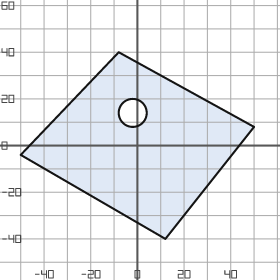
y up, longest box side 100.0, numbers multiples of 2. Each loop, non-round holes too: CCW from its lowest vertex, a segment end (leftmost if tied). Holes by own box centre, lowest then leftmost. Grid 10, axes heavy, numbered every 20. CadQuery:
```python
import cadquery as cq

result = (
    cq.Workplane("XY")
    .moveTo(12.0, -40.0)
    .lineTo(50.0, 8.0)
    .lineTo(-8.0, 40.0)
    .lineTo(-50.0, -4.0)
    .close()
    .moveTo(-2.0, 14.0)
    .circle(6.0)
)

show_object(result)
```